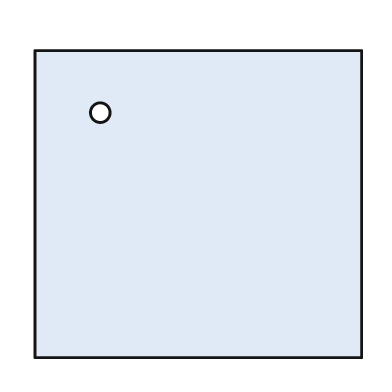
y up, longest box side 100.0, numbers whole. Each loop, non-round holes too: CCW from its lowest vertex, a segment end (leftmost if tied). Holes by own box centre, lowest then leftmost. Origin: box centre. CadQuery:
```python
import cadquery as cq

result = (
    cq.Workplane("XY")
    .moveTo(-50.0, -47.0)
    .lineTo(50.0, -47.0)
    .lineTo(50.0, 47.0)
    .lineTo(-50.0, 47.0)
    .close()
    .moveTo(-30.0, 28.0)
    .circle(3.0)
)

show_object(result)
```